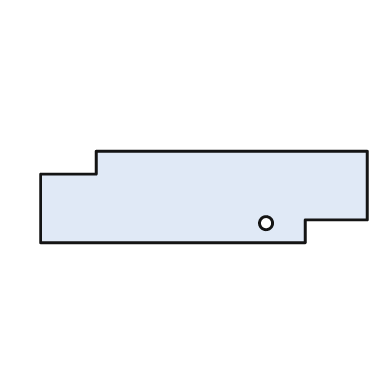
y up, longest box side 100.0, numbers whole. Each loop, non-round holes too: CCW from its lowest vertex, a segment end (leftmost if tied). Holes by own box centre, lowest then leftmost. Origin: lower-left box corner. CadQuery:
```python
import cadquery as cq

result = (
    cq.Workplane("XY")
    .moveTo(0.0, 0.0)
    .lineTo(81.0, 0.0)
    .lineTo(81.0, 7.0)
    .lineTo(100.0, 7.0)
    .lineTo(100.0, 28.0)
    .lineTo(17.0, 28.0)
    .lineTo(17.0, 21.0)
    .lineTo(0.0, 21.0)
    .close()
    .moveTo(69.0, 6.0)
    .circle(2.0)
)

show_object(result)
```